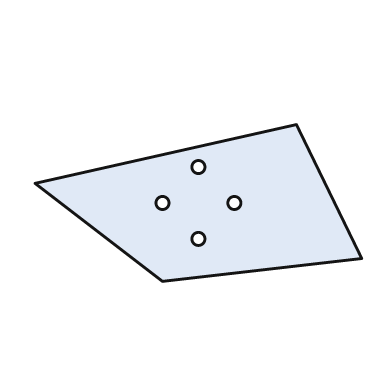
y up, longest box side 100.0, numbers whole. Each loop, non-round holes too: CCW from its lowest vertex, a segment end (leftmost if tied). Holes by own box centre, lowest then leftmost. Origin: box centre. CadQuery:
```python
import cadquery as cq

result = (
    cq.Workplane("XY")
    .moveTo(-11.0, -24.0)
    .lineTo(50.0, -17.0)
    .lineTo(30.0, 24.0)
    .lineTo(-50.0, 6.0)
    .close()
    .moveTo(0.0, -11.0)
    .circle(2.0)
    .moveTo(-11.0, 0.0)
    .circle(2.0)
    .moveTo(11.0, 0.0)
    .circle(2.0)
    .moveTo(0.0, 11.0)
    .circle(2.0)
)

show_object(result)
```